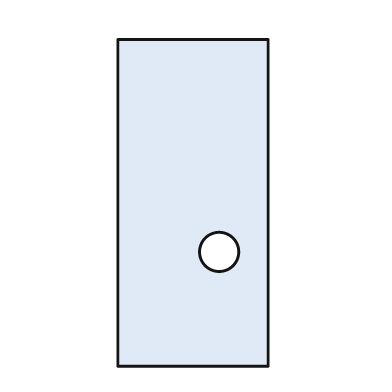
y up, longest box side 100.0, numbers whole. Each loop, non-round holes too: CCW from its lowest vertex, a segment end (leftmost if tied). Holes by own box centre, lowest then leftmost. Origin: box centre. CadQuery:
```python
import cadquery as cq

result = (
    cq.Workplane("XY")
    .moveTo(-23.0, -50.0)
    .lineTo(23.0, -50.0)
    .lineTo(23.0, 50.0)
    .lineTo(-23.0, 50.0)
    .close()
    .moveTo(8.0, -15.0)
    .circle(6.0)
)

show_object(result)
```